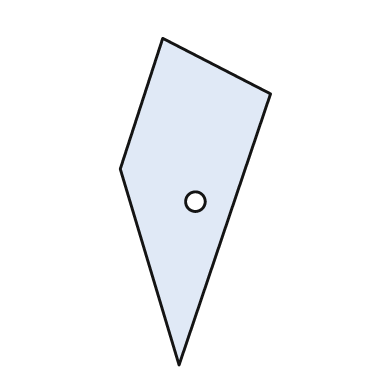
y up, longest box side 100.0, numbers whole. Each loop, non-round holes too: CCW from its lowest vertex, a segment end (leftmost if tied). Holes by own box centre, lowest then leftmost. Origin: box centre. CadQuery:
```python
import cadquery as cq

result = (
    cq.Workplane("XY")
    .moveTo(-5.0, -50.0)
    .lineTo(23.0, 33.0)
    .lineTo(-10.0, 50.0)
    .lineTo(-23.0, 10.0)
    .close()
    .moveTo(0.0, 0.0)
    .circle(3.0)
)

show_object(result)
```